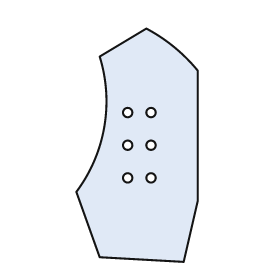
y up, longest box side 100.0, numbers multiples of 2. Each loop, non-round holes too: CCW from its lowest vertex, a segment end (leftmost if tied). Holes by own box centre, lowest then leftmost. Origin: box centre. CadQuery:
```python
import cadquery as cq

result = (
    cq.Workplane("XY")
    .moveTo(20.0, -50.0)
    .lineTo(26.0, -24.0)
    .lineTo(26.0, 32.0)
    .threePointArc((16.0, 42.0), (4.0, 50.0))
    .lineTo(-16.0, 38.0)
    .threePointArc((-14.0, 8.0), (-26.0, -20.0))
    .lineTo(-16.0, -48.0)
    .close()
    .moveTo(-4.0, -14.0)
    .circle(2.0)
    .moveTo(6.0, -14.0)
    .circle(2.0)
    .moveTo(-4.0, 0.0)
    .circle(2.0)
    .moveTo(6.0, 0.0)
    .circle(2.0)
    .moveTo(-4.0, 14.0)
    .circle(2.0)
    .moveTo(6.0, 14.0)
    .circle(2.0)
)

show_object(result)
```